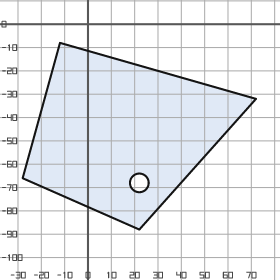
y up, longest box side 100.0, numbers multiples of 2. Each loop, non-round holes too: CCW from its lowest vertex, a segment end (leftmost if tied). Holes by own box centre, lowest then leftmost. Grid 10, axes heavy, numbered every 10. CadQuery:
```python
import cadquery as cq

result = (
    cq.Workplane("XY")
    .moveTo(22.0, -88.0)
    .lineTo(72.0, -32.0)
    .lineTo(-12.0, -8.0)
    .lineTo(-28.0, -66.0)
    .close()
    .moveTo(22.0, -68.0)
    .circle(4.0)
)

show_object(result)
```